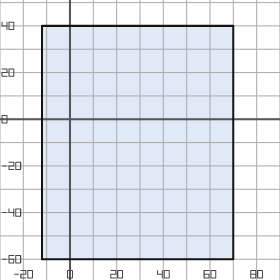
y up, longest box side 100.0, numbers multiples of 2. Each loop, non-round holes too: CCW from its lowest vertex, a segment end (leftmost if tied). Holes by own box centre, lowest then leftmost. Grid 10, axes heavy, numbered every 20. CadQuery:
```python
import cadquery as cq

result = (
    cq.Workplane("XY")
    .moveTo(-12.0, -60.0)
    .lineTo(70.0, -60.0)
    .lineTo(70.0, 40.0)
    .lineTo(-12.0, 40.0)
    .close()
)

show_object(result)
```